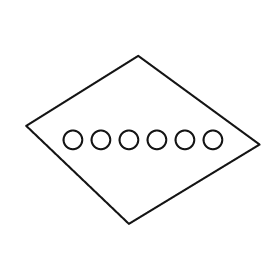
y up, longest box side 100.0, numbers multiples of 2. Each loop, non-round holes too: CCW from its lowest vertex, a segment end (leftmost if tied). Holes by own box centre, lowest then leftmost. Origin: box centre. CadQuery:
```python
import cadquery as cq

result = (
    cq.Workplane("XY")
    .moveTo(-6.0, -36.0)
    .lineTo(50.0, -2.0)
    .lineTo(-2.0, 36.0)
    .lineTo(-50.0, 6.0)
    .close()
    .moveTo(-30.0, 0.0)
    .circle(4.0)
    .moveTo(-18.0, 0.0)
    .circle(4.0)
    .moveTo(-6.0, 0.0)
    .circle(4.0)
    .moveTo(6.0, 0.0)
    .circle(4.0)
    .moveTo(18.0, 0.0)
    .circle(4.0)
    .moveTo(30.0, 0.0)
    .circle(4.0)
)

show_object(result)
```